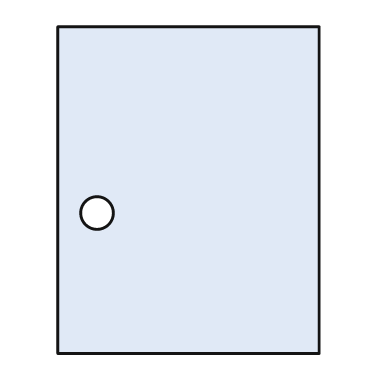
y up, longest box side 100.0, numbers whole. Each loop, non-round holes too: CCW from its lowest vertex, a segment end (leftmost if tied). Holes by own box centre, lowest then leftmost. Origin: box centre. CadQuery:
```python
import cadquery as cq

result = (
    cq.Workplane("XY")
    .moveTo(-40.0, -50.0)
    .lineTo(40.0, -50.0)
    .lineTo(40.0, 50.0)
    .lineTo(-40.0, 50.0)
    .close()
    .moveTo(-28.0, -7.0)
    .circle(5.0)
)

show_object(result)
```